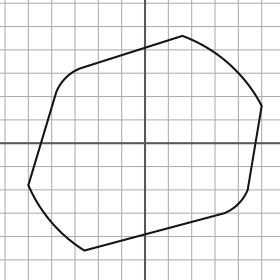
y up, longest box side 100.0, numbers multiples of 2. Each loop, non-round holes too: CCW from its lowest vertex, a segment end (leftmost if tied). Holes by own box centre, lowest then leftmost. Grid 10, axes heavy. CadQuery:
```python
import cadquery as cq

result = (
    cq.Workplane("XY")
    .moveTo(-26.0, -46.0)
    .lineTo(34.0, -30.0)
    .threePointArc((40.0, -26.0), (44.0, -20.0))
    .lineTo(50.0, 16.0)
    .threePointArc((36.0, 34.0), (16.0, 46.0))
    .lineTo(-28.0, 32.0)
    .threePointArc((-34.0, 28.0), (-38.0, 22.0))
    .lineTo(-50.0, -18.0)
    .threePointArc((-40.0, -34.0), (-26.0, -46.0))
    .close()
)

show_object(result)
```